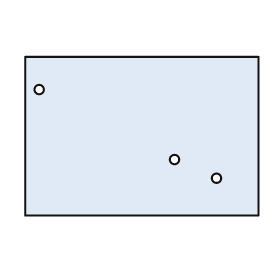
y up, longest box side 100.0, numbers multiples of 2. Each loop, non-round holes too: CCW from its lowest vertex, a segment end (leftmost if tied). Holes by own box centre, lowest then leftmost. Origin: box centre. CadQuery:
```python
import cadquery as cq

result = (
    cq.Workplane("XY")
    .moveTo(-50.0, -34.0)
    .lineTo(50.0, -34.0)
    .lineTo(50.0, 34.0)
    .lineTo(-50.0, 34.0)
    .close()
    .moveTo(32.0, -18.0)
    .circle(2.0)
    .moveTo(14.0, -10.0)
    .circle(2.0)
    .moveTo(-44.0, 20.0)
    .circle(2.0)
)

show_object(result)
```